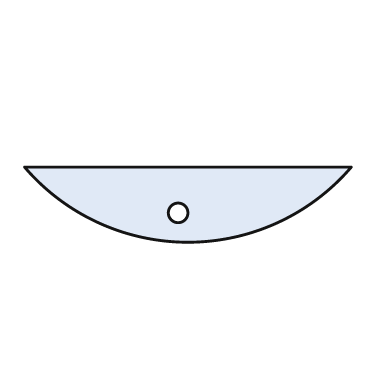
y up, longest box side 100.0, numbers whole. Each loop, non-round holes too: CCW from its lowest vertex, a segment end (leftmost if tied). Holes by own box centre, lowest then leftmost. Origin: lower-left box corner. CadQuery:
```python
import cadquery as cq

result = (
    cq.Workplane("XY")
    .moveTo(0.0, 23.0)
    .threePointArc((50.0, 0.0), (100.0, 23.0))
    .close()
    .moveTo(47.0, 9.0)
    .circle(3.0)
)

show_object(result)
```